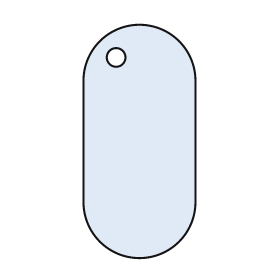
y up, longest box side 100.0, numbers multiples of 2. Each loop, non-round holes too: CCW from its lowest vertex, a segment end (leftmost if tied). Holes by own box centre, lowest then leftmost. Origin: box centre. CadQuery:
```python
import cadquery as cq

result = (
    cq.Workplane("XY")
    .moveTo(-24.0, -26.0)
    .threePointArc((0.0, -50.0), (24.0, -26.0))
    .lineTo(24.0, 26.0)
    .threePointArc((0.0, 50.0), (-24.0, 26.0))
    .close()
    .moveTo(-10.0, 36.0)
    .circle(4.0)
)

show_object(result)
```